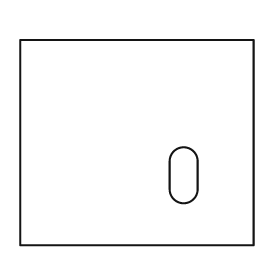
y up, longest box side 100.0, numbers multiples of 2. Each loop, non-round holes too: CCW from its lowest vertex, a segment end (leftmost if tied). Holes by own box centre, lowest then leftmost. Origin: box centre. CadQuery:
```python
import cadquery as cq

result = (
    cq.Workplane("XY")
    .moveTo(-50.0, -44.0)
    .lineTo(50.0, -44.0)
    .lineTo(50.0, 44.0)
    .lineTo(-50.0, 44.0)
    .close()
    .moveTo(14.0, -20.0)
    .threePointArc((20.0, -26.0), (26.0, -20.0))
    .lineTo(26.0, -8.0)
    .threePointArc((20.0, -2.0), (14.0, -8.0))
    .close()
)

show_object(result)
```